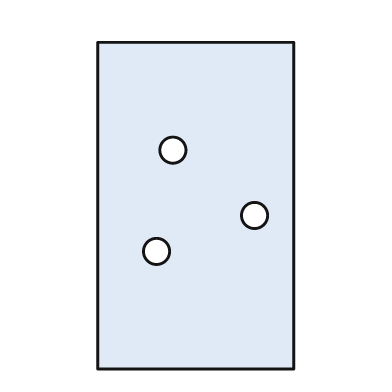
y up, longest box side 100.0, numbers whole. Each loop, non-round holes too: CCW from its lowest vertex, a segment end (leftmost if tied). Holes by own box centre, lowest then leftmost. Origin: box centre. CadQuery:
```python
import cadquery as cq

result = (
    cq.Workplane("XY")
    .moveTo(-30.0, -50.0)
    .lineTo(30.0, -50.0)
    .lineTo(30.0, 50.0)
    .lineTo(-30.0, 50.0)
    .close()
    .moveTo(-12.0, -14.0)
    .circle(4.0)
    .moveTo(18.0, -3.0)
    .circle(4.0)
    .moveTo(-7.0, 17.0)
    .circle(4.0)
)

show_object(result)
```